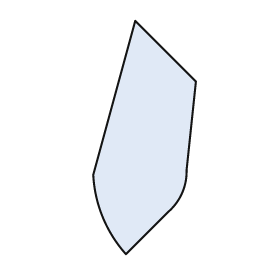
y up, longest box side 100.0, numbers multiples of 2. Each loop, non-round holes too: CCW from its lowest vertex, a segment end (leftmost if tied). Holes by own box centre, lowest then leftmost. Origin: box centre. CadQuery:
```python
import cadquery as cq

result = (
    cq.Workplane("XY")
    .moveTo(-8.0, -50.0)
    .lineTo(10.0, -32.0)
    .threePointArc((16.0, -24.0), (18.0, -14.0))
    .lineTo(22.0, 24.0)
    .lineTo(-4.0, 50.0)
    .lineTo(-22.0, -16.0)
    .threePointArc((-18.0, -34.0), (-8.0, -50.0))
    .close()
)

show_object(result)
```